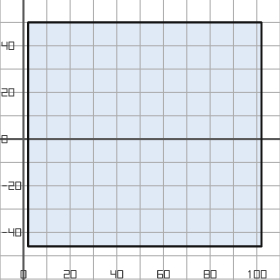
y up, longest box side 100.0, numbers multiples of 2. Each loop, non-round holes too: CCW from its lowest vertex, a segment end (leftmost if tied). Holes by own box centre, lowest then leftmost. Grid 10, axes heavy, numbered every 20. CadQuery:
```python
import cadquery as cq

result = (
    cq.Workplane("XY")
    .moveTo(2.0, -46.0)
    .lineTo(102.0, -46.0)
    .lineTo(102.0, 50.0)
    .lineTo(2.0, 50.0)
    .close()
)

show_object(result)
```